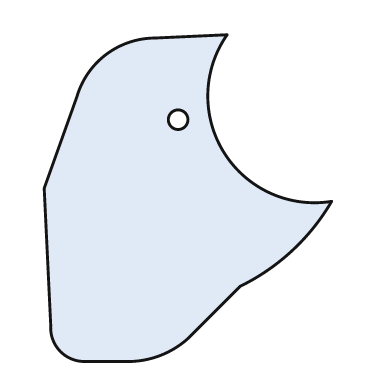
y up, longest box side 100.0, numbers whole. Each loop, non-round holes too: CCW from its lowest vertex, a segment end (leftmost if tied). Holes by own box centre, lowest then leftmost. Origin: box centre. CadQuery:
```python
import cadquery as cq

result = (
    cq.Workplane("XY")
    .moveTo(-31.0, -50.0)
    .lineTo(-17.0, -50.0)
    .threePointArc((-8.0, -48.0), (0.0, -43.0))
    .lineTo(16.0, -27.0)
    .threePointArc((32.0, -16.0), (44.0, -1.0))
    .threePointArc((11.0, 14.0), (12.0, 50.0))
    .lineTo(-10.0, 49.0)
    .threePointArc((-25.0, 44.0), (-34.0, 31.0))
    .lineTo(-44.0, 3.0)
    .lineTo(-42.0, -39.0)
    .threePointArc((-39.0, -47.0), (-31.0, -50.0))
    .close()
    .moveTo(-3.0, 24.0)
    .circle(3.0)
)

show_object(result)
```